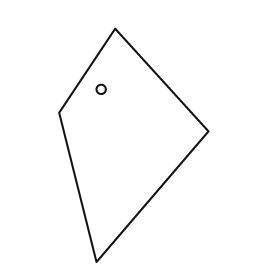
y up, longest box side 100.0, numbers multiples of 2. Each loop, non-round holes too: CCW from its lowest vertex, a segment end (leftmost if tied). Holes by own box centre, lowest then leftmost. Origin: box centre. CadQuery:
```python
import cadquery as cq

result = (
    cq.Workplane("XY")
    .moveTo(-16.0, -50.0)
    .lineTo(32.0, 6.0)
    .lineTo(-8.0, 50.0)
    .lineTo(-32.0, 14.0)
    .close()
    .moveTo(-14.0, 24.0)
    .circle(2.0)
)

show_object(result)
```